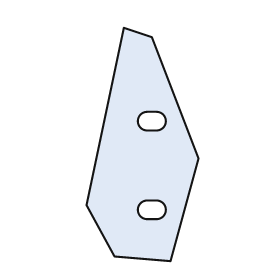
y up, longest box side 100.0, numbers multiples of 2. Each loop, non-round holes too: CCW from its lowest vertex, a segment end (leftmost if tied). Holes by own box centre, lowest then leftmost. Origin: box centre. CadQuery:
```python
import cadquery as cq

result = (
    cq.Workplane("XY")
    .moveTo(12.0, -50.0)
    .lineTo(24.0, -6.0)
    .lineTo(4.0, 46.0)
    .lineTo(-8.0, 50.0)
    .lineTo(-24.0, -26.0)
    .lineTo(-12.0, -48.0)
    .close()
    .moveTo(2.0, -32.0)
    .lineTo(6.0, -32.0)
    .threePointArc((10.0, -28.0), (6.0, -24.0))
    .lineTo(2.0, -24.0)
    .threePointArc((-2.0, -28.0), (2.0, -32.0))
    .close()
    .moveTo(2.0, 6.0)
    .lineTo(6.0, 6.0)
    .threePointArc((10.0, 10.0), (6.0, 14.0))
    .lineTo(2.0, 14.0)
    .threePointArc((-2.0, 10.0), (2.0, 6.0))
    .close()
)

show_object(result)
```